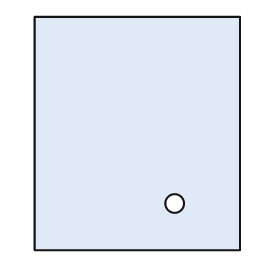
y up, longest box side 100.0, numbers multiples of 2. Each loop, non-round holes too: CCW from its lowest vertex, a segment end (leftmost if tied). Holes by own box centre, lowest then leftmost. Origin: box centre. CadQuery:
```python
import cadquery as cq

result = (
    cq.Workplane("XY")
    .moveTo(-44.0, -50.0)
    .lineTo(44.0, -50.0)
    .lineTo(44.0, 50.0)
    .lineTo(-44.0, 50.0)
    .close()
    .moveTo(16.0, -30.0)
    .circle(4.0)
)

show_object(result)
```